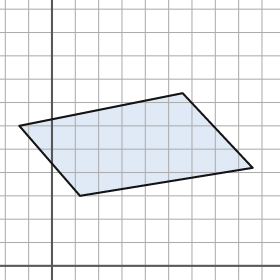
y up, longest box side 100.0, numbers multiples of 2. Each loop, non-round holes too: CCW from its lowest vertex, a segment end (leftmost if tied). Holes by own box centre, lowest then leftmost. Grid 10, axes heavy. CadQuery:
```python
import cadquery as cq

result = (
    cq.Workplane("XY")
    .moveTo(12.0, 30.0)
    .lineTo(86.0, 42.0)
    .lineTo(56.0, 74.0)
    .lineTo(-14.0, 60.0)
    .close()
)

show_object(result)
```